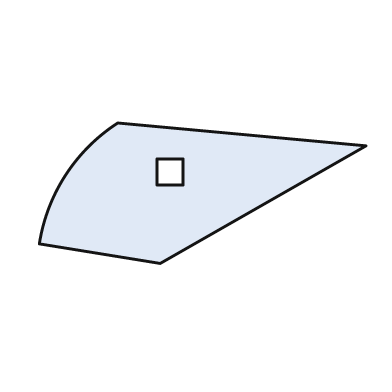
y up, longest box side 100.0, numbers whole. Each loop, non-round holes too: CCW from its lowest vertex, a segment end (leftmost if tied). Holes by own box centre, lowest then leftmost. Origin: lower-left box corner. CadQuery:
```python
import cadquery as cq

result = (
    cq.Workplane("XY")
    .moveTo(37.0, 0.0)
    .lineTo(100.0, 36.0)
    .lineTo(24.0, 43.0)
    .threePointArc((8.0, 27.0), (0.0, 6.0))
    .close()
    .moveTo(36.0, 24.0)
    .lineTo(44.0, 24.0)
    .lineTo(44.0, 32.0)
    .lineTo(36.0, 32.0)
    .close()
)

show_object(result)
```